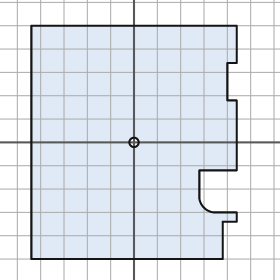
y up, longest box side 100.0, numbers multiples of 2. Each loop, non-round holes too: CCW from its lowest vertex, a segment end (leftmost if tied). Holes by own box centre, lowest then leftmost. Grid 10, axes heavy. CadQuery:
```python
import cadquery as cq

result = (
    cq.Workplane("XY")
    .moveTo(-44.0, -50.0)
    .lineTo(38.0, -50.0)
    .lineTo(38.0, -34.0)
    .lineTo(44.0, -34.0)
    .lineTo(44.0, -30.0)
    .lineTo(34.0, -30.0)
    .threePointArc((30.0, -28.0), (28.0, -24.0))
    .lineTo(28.0, -12.0)
    .lineTo(44.0, -12.0)
    .lineTo(44.0, 18.0)
    .lineTo(40.0, 18.0)
    .lineTo(40.0, 34.0)
    .lineTo(44.0, 34.0)
    .lineTo(44.0, 50.0)
    .lineTo(-44.0, 50.0)
    .close()
    .moveTo(0.0, 0.0)
    .circle(2.0)
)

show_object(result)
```